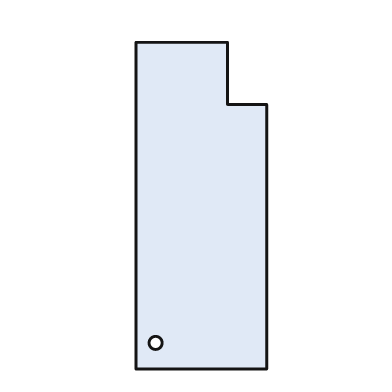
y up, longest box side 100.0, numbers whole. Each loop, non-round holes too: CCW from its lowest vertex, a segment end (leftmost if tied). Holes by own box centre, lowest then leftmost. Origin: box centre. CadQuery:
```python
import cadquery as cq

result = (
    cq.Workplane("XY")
    .moveTo(-20.0, -50.0)
    .lineTo(20.0, -50.0)
    .lineTo(20.0, 31.0)
    .lineTo(8.0, 31.0)
    .lineTo(8.0, 50.0)
    .lineTo(-20.0, 50.0)
    .close()
    .moveTo(-14.0, -42.0)
    .circle(2.0)
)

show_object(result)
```